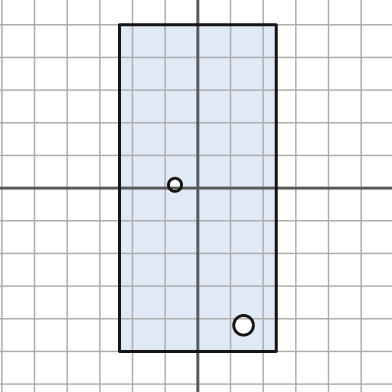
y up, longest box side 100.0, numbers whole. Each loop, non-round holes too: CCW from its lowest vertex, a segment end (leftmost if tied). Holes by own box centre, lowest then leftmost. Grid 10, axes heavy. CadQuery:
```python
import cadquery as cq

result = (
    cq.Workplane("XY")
    .moveTo(-24.0, -50.0)
    .lineTo(24.0, -50.0)
    .lineTo(24.0, 50.0)
    .lineTo(-24.0, 50.0)
    .close()
    .moveTo(14.0, -42.0)
    .circle(3.0)
    .moveTo(-7.0, 1.0)
    .circle(2.0)
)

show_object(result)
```